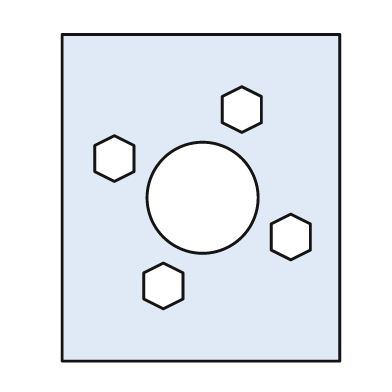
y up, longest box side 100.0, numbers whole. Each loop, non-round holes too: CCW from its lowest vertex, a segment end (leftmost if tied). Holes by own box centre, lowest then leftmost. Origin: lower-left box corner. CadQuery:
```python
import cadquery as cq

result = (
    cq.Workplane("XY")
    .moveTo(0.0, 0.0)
    .lineTo(85.0, 0.0)
    .lineTo(85.0, 100.0)
    .lineTo(0.0, 100.0)
    .close()
    .moveTo(31.0, 16.0)
    .lineTo(37.0, 19.0)
    .lineTo(37.0, 27.0)
    .lineTo(31.0, 30.0)
    .lineTo(25.0, 27.0)
    .lineTo(25.0, 19.0)
    .close()
    .moveTo(70.0, 31.0)
    .lineTo(76.0, 34.0)
    .lineTo(76.0, 42.0)
    .lineTo(70.0, 45.0)
    .lineTo(64.0, 42.0)
    .lineTo(64.0, 34.0)
    .close()
    .moveTo(43.0, 50.0)
    .circle(17.0)
    .moveTo(16.0, 55.0)
    .lineTo(22.0, 58.0)
    .lineTo(22.0, 66.0)
    .lineTo(16.0, 69.0)
    .lineTo(10.0, 66.0)
    .lineTo(10.0, 58.0)
    .close()
    .moveTo(55.0, 70.0)
    .lineTo(61.0, 73.0)
    .lineTo(61.0, 81.0)
    .lineTo(55.0, 84.0)
    .lineTo(49.0, 81.0)
    .lineTo(49.0, 73.0)
    .close()
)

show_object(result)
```